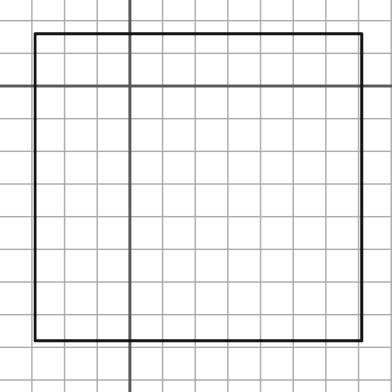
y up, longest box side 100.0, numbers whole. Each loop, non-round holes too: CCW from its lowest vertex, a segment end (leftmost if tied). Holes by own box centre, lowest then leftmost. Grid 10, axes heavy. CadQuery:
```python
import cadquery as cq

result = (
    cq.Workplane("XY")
    .moveTo(-29.0, -78.0)
    .lineTo(71.0, -78.0)
    .lineTo(71.0, 16.0)
    .lineTo(-29.0, 16.0)
    .close()
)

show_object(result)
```